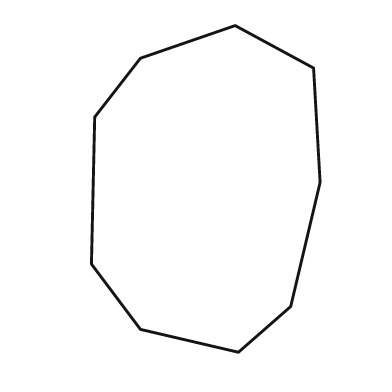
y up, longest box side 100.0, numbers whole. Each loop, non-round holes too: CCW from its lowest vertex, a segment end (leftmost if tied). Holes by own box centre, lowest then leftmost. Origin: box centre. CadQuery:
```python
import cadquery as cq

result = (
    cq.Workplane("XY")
    .moveTo(10.0, -50.0)
    .lineTo(26.0, -36.0)
    .lineTo(35.0, 2.0)
    .lineTo(33.0, 37.0)
    .lineTo(9.0, 50.0)
    .lineTo(-20.0, 40.0)
    .lineTo(-34.0, 22.0)
    .lineTo(-35.0, -23.0)
    .lineTo(-20.0, -43.0)
    .close()
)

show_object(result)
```